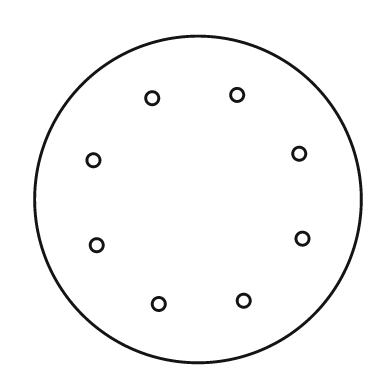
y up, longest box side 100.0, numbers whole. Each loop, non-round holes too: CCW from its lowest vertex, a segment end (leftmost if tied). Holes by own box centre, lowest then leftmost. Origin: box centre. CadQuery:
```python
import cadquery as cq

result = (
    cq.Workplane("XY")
    .moveTo(0.0, 0.0)
    .circle(50.0)
    .moveTo(-12.0, -32.0)
    .circle(2.0)
    .moveTo(14.0, -31.0)
    .circle(2.0)
    .moveTo(-31.0, -14.0)
    .circle(2.0)
    .moveTo(32.0, -12.0)
    .circle(2.0)
    .moveTo(-32.0, 12.0)
    .circle(2.0)
    .moveTo(31.0, 14.0)
    .circle(2.0)
    .moveTo(-14.0, 31.0)
    .circle(2.0)
    .moveTo(12.0, 32.0)
    .circle(2.0)
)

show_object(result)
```